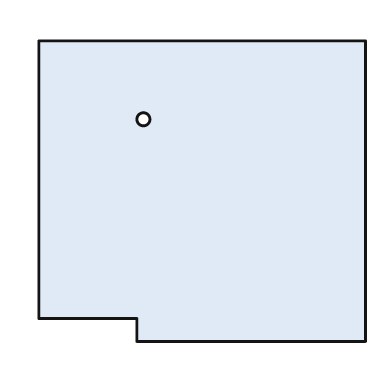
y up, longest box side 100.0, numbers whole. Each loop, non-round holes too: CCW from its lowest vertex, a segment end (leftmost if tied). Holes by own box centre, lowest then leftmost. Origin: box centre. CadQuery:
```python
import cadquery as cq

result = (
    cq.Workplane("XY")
    .moveTo(-20.0, -46.0)
    .lineTo(50.0, -46.0)
    .lineTo(50.0, 46.0)
    .lineTo(-50.0, 46.0)
    .lineTo(-50.0, -39.0)
    .lineTo(-20.0, -39.0)
    .close()
    .moveTo(-18.0, 22.0)
    .circle(2.0)
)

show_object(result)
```